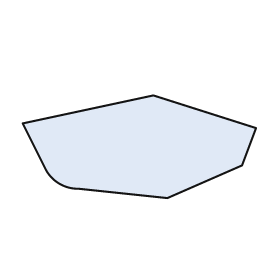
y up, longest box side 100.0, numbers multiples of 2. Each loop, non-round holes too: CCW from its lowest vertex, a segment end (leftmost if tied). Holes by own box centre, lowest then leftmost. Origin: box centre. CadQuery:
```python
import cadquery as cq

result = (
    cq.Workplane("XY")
    .moveTo(12.0, -22.0)
    .lineTo(44.0, -8.0)
    .lineTo(50.0, 8.0)
    .lineTo(6.0, 22.0)
    .lineTo(-50.0, 10.0)
    .lineTo(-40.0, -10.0)
    .threePointArc((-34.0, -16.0), (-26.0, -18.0))
    .close()
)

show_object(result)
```